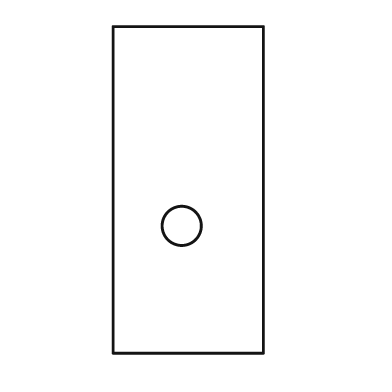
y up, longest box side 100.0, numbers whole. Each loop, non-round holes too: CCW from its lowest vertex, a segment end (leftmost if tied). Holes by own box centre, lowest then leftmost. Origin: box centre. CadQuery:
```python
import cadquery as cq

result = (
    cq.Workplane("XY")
    .moveTo(-23.0, -50.0)
    .lineTo(23.0, -50.0)
    .lineTo(23.0, 50.0)
    .lineTo(-23.0, 50.0)
    .close()
    .moveTo(-2.0, -11.0)
    .circle(6.0)
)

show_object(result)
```